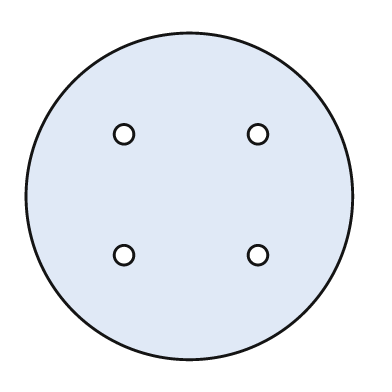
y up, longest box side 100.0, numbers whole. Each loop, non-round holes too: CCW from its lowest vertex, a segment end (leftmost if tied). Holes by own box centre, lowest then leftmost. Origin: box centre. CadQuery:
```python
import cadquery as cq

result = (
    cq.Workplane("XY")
    .moveTo(0.0, 0.0)
    .circle(50.0)
    .moveTo(-20.0, -18.0)
    .circle(3.0)
    .moveTo(21.0, -18.0)
    .circle(3.0)
    .moveTo(-20.0, 19.0)
    .circle(3.0)
    .moveTo(21.0, 19.0)
    .circle(3.0)
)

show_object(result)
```